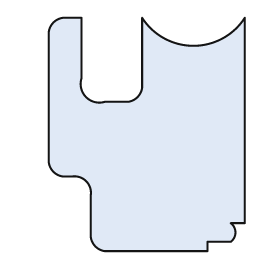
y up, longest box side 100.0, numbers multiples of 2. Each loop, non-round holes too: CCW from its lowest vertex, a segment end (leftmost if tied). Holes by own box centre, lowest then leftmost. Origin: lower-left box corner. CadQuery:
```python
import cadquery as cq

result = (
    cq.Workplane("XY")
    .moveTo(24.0, 0.0)
    .lineTo(68.0, 0.0)
    .lineTo(68.0, 4.0)
    .lineTo(78.0, 4.0)
    .threePointArc((80.0, 8.0), (78.0, 12.0))
    .lineTo(84.0, 12.0)
    .lineTo(84.0, 100.0)
    .threePointArc((62.0, 88.0), (40.0, 100.0))
    .lineTo(40.0, 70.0)
    .threePointArc((38.0, 66.0), (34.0, 64.0))
    .lineTo(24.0, 64.0)
    .threePointArc((16.0, 66.0), (14.0, 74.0))
    .lineTo(14.0, 100.0)
    .lineTo(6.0, 100.0)
    .threePointArc((2.0, 98.0), (0.0, 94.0))
    .lineTo(0.0, 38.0)
    .threePointArc((2.0, 34.0), (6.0, 32.0))
    .lineTo(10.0, 32.0)
    .threePointArc((16.0, 30.0), (18.0, 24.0))
    .lineTo(18.0, 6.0)
    .threePointArc((20.0, 2.0), (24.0, 0.0))
    .close()
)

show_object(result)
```